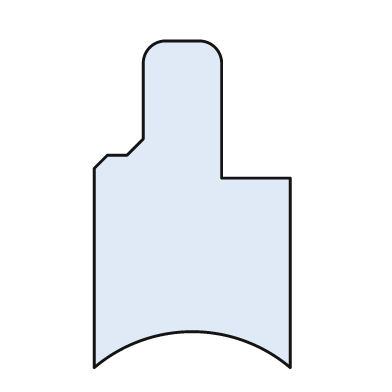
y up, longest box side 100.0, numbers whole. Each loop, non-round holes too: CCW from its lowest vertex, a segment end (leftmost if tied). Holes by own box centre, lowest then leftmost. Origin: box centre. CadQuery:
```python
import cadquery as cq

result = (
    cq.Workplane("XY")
    .moveTo(-30.0, -50.0)
    .threePointArc((0.0, -39.0), (30.0, -50.0))
    .lineTo(30.0, 8.0)
    .lineTo(9.0, 8.0)
    .lineTo(9.0, 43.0)
    .threePointArc((7.0, 48.0), (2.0, 50.0))
    .lineTo(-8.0, 50.0)
    .threePointArc((-13.0, 48.0), (-15.0, 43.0))
    .lineTo(-15.0, 20.0)
    .lineTo(-20.0, 15.0)
    .lineTo(-26.0, 15.0)
    .lineTo(-30.0, 11.0)
    .close()
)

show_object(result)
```